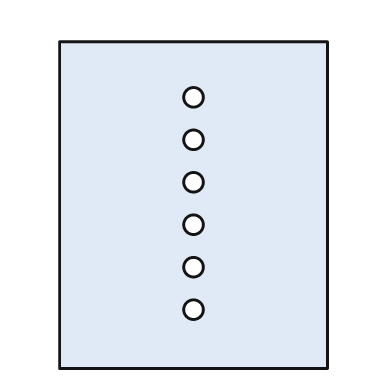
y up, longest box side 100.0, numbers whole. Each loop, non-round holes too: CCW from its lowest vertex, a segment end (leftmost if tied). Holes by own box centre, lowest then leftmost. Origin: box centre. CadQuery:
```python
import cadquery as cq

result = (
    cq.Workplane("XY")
    .moveTo(-41.0, -50.0)
    .lineTo(41.0, -50.0)
    .lineTo(41.0, 50.0)
    .lineTo(-41.0, 50.0)
    .close()
    .moveTo(0.0, -32.0)
    .circle(3.0)
    .moveTo(0.0, -19.0)
    .circle(3.0)
    .moveTo(0.0, -6.0)
    .circle(3.0)
    .moveTo(0.0, 7.0)
    .circle(3.0)
    .moveTo(0.0, 20.0)
    .circle(3.0)
    .moveTo(0.0, 33.0)
    .circle(3.0)
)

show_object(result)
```